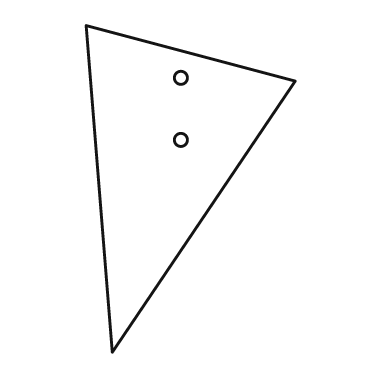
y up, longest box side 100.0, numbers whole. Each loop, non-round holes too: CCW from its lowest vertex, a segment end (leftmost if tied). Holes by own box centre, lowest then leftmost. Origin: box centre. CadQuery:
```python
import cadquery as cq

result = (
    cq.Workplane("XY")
    .moveTo(-24.0, -50.0)
    .lineTo(32.0, 33.0)
    .lineTo(-32.0, 50.0)
    .close()
    .moveTo(-3.0, 15.0)
    .circle(2.0)
    .moveTo(-3.0, 34.0)
    .circle(2.0)
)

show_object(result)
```